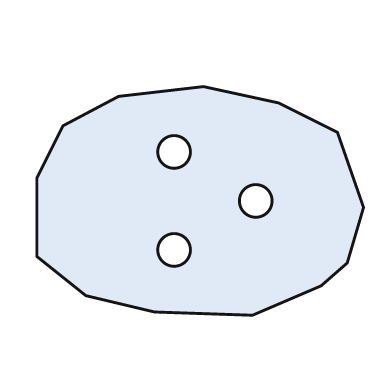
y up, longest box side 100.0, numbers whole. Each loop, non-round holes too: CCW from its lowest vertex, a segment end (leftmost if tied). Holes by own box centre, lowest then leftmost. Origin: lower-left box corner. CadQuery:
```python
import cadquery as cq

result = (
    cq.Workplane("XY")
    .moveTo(66.0, 0.0)
    .lineTo(87.0, 9.0)
    .lineTo(95.0, 16.0)
    .lineTo(100.0, 33.0)
    .lineTo(92.0, 56.0)
    .lineTo(74.0, 65.0)
    .lineTo(51.0, 70.0)
    .lineTo(25.0, 67.0)
    .lineTo(8.0, 58.0)
    .lineTo(0.0, 42.0)
    .lineTo(0.0, 18.0)
    .lineTo(15.0, 6.0)
    .lineTo(36.0, 1.0)
    .close()
    .moveTo(42.0, 20.0)
    .circle(5.0)
    .moveTo(67.0, 35.0)
    .circle(5.0)
    .moveTo(42.0, 50.0)
    .circle(5.0)
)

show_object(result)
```